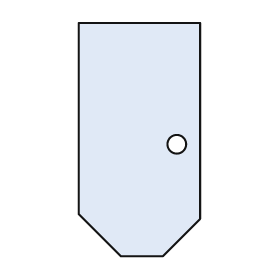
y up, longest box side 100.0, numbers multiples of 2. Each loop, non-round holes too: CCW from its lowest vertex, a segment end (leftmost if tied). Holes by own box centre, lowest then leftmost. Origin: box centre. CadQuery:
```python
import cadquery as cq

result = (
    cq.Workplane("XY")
    .moveTo(-8.0, -50.0)
    .lineTo(10.0, -50.0)
    .lineTo(26.0, -34.0)
    .lineTo(26.0, 50.0)
    .lineTo(-26.0, 50.0)
    .lineTo(-26.0, -32.0)
    .close()
    .moveTo(16.0, -2.0)
    .circle(4.0)
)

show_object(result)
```